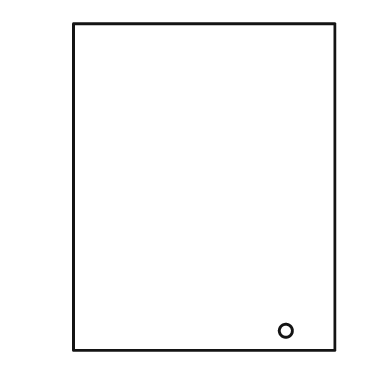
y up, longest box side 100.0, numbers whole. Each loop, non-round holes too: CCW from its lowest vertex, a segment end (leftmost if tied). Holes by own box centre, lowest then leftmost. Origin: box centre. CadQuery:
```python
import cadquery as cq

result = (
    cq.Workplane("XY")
    .moveTo(-40.0, -50.0)
    .lineTo(40.0, -50.0)
    .lineTo(40.0, 50.0)
    .lineTo(-40.0, 50.0)
    .close()
    .moveTo(25.0, -44.0)
    .circle(2.0)
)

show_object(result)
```